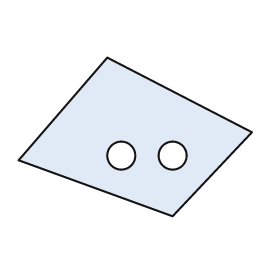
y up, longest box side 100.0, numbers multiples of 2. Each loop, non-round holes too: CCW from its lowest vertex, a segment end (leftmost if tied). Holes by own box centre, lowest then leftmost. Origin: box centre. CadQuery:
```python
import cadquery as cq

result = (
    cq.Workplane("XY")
    .moveTo(16.0, -34.0)
    .lineTo(50.0, 2.0)
    .lineTo(-12.0, 34.0)
    .lineTo(-50.0, -10.0)
    .close()
    .moveTo(-6.0, -8.0)
    .circle(6.0)
    .moveTo(16.0, -8.0)
    .circle(6.0)
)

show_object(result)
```